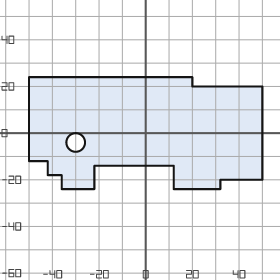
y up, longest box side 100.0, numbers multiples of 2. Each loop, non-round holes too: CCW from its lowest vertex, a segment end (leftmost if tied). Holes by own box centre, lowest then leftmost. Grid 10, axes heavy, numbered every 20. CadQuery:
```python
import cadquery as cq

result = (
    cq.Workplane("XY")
    .moveTo(-36.0, -24.0)
    .lineTo(-22.0, -24.0)
    .lineTo(-22.0, -14.0)
    .lineTo(12.0, -14.0)
    .lineTo(12.0, -24.0)
    .lineTo(32.0, -24.0)
    .lineTo(32.0, -20.0)
    .lineTo(50.0, -20.0)
    .lineTo(50.0, 20.0)
    .lineTo(20.0, 20.0)
    .lineTo(20.0, 24.0)
    .lineTo(-50.0, 24.0)
    .lineTo(-50.0, -12.0)
    .lineTo(-42.0, -12.0)
    .lineTo(-42.0, -18.0)
    .lineTo(-36.0, -18.0)
    .close()
    .moveTo(-30.0, -4.0)
    .circle(4.0)
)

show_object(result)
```